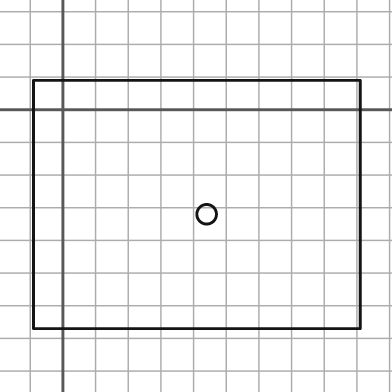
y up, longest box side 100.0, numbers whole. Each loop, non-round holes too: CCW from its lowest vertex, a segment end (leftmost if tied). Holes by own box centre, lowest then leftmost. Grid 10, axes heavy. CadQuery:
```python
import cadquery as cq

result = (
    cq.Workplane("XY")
    .moveTo(-9.0, -67.0)
    .lineTo(91.0, -67.0)
    .lineTo(91.0, 9.0)
    .lineTo(-9.0, 9.0)
    .close()
    .moveTo(44.0, -32.0)
    .circle(3.0)
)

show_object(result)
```